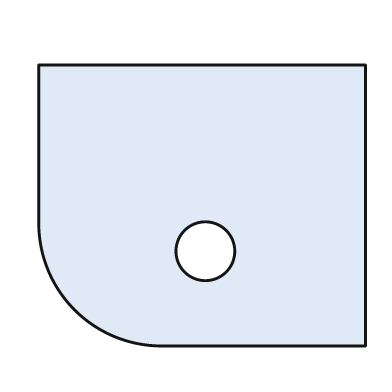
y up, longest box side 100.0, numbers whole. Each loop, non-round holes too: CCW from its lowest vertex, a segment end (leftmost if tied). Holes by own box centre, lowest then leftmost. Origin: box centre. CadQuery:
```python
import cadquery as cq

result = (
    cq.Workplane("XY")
    .moveTo(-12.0, -43.0)
    .lineTo(50.0, -43.0)
    .lineTo(50.0, 43.0)
    .lineTo(-50.0, 43.0)
    .lineTo(-50.0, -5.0)
    .threePointArc((-39.0, -32.0), (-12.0, -43.0))
    .close()
    .moveTo(1.0, -14.0)
    .circle(9.0)
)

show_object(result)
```